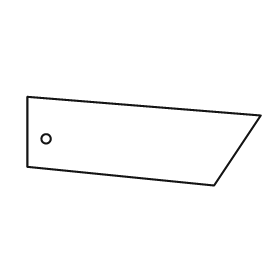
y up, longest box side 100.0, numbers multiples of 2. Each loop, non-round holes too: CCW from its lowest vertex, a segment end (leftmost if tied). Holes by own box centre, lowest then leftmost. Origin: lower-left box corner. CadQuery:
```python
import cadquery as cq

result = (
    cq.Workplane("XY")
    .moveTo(80.0, 0.0)
    .lineTo(100.0, 30.0)
    .lineTo(0.0, 38.0)
    .lineTo(0.0, 8.0)
    .close()
    .moveTo(8.0, 20.0)
    .circle(2.0)
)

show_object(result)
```